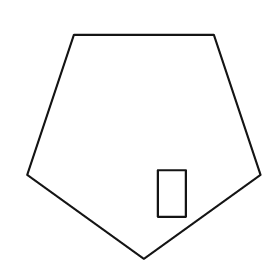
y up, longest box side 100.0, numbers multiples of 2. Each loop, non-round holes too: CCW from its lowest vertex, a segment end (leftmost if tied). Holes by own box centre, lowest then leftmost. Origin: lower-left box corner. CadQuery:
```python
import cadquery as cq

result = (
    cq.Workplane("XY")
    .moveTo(50.0, 0.0)
    .lineTo(100.0, 36.0)
    .lineTo(80.0, 96.0)
    .lineTo(20.0, 96.0)
    .lineTo(0.0, 36.0)
    .close()
    .moveTo(56.0, 18.0)
    .lineTo(68.0, 18.0)
    .lineTo(68.0, 38.0)
    .lineTo(56.0, 38.0)
    .close()
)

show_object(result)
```